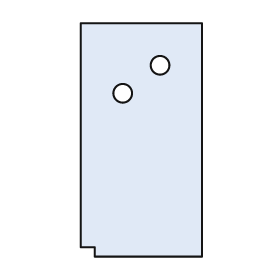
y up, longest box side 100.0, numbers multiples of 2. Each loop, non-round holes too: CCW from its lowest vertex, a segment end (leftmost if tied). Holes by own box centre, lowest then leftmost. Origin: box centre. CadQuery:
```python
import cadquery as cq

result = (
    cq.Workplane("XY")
    .moveTo(-20.0, -50.0)
    .lineTo(26.0, -50.0)
    .lineTo(26.0, 50.0)
    .lineTo(-26.0, 50.0)
    .lineTo(-26.0, -46.0)
    .lineTo(-20.0, -46.0)
    .close()
    .moveTo(-8.0, 20.0)
    .circle(4.0)
    .moveTo(8.0, 32.0)
    .circle(4.0)
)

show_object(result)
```